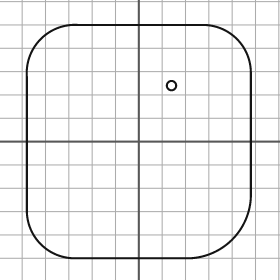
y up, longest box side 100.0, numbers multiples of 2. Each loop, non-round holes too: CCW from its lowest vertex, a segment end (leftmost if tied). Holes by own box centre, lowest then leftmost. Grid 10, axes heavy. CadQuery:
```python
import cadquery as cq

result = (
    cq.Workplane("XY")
    .moveTo(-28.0, -50.0)
    .lineTo(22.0, -50.0)
    .threePointArc((40.0, -42.0), (48.0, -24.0))
    .lineTo(48.0, 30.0)
    .threePointArc((42.0, 44.0), (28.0, 50.0))
    .lineTo(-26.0, 50.0)
    .threePointArc((-42.0, 44.0), (-48.0, 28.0))
    .lineTo(-48.0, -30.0)
    .threePointArc((-42.0, -44.0), (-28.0, -50.0))
    .close()
    .moveTo(14.0, 24.0)
    .circle(2.0)
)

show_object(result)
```